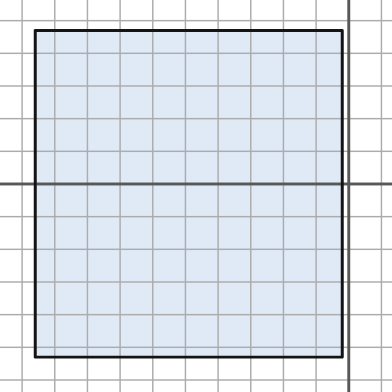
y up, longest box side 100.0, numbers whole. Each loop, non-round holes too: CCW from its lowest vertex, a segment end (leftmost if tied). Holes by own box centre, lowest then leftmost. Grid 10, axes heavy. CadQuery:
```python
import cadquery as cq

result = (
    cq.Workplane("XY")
    .moveTo(-96.0, -53.0)
    .lineTo(-2.0, -53.0)
    .lineTo(-2.0, 47.0)
    .lineTo(-96.0, 47.0)
    .close()
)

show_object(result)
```